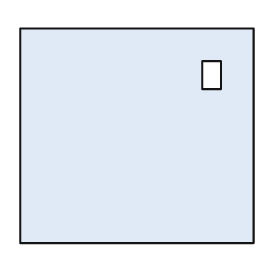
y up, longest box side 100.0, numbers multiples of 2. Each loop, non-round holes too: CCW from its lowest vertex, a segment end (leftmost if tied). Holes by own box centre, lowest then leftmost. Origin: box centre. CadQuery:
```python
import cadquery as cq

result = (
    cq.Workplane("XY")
    .moveTo(-50.0, -46.0)
    .lineTo(50.0, -46.0)
    .lineTo(50.0, 46.0)
    .lineTo(-50.0, 46.0)
    .close()
    .moveTo(28.0, 20.0)
    .lineTo(36.0, 20.0)
    .lineTo(36.0, 32.0)
    .lineTo(28.0, 32.0)
    .close()
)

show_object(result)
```